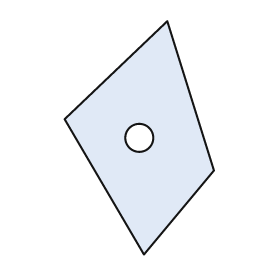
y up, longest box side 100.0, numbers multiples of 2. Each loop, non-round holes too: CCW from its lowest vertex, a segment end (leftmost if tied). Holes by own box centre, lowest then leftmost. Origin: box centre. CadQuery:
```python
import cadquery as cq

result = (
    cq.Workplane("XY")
    .moveTo(2.0, -50.0)
    .lineTo(32.0, -14.0)
    .lineTo(12.0, 50.0)
    .lineTo(-32.0, 8.0)
    .close()
    .moveTo(0.0, 0.0)
    .circle(6.0)
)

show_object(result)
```